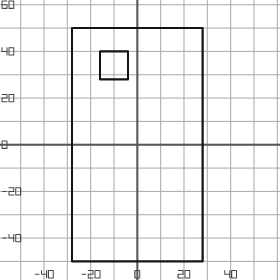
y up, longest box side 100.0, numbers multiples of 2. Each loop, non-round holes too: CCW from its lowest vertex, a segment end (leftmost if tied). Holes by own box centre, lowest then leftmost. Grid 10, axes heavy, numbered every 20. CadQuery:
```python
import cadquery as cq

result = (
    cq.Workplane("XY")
    .moveTo(-28.0, -50.0)
    .lineTo(28.0, -50.0)
    .lineTo(28.0, 50.0)
    .lineTo(-28.0, 50.0)
    .close()
    .moveTo(-16.0, 28.0)
    .lineTo(-4.0, 28.0)
    .lineTo(-4.0, 40.0)
    .lineTo(-16.0, 40.0)
    .close()
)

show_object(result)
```